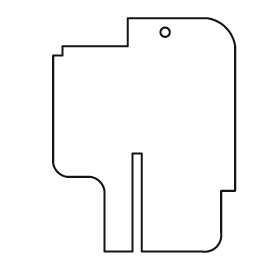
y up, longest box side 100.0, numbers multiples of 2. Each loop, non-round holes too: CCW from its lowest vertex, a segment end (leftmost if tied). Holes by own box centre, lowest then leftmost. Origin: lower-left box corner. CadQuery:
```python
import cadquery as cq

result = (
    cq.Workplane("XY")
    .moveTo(22.0, 0.0)
    .lineTo(34.0, 0.0)
    .lineTo(34.0, 42.0)
    .lineTo(38.0, 42.0)
    .lineTo(38.0, 0.0)
    .lineTo(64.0, 0.0)
    .threePointArc((70.0, 2.0), (72.0, 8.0))
    .lineTo(72.0, 26.0)
    .lineTo(78.0, 26.0)
    .lineTo(78.0, 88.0)
    .threePointArc((74.0, 96.0), (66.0, 100.0))
    .lineTo(32.0, 100.0)
    .lineTo(32.0, 88.0)
    .lineTo(4.0, 88.0)
    .lineTo(4.0, 84.0)
    .lineTo(0.0, 84.0)
    .lineTo(0.0, 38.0)
    .threePointArc((2.0, 34.0), (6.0, 32.0))
    .lineTo(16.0, 32.0)
    .threePointArc((20.0, 30.0), (22.0, 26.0))
    .close()
    .moveTo(48.0, 94.0)
    .circle(2.0)
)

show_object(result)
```